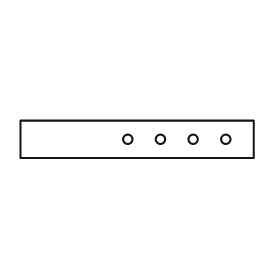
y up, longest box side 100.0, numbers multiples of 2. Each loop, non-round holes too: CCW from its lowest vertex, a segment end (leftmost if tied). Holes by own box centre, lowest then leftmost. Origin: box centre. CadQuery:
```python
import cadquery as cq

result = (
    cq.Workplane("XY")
    .moveTo(-50.0, -8.0)
    .lineTo(50.0, -8.0)
    .lineTo(50.0, 8.0)
    .lineTo(-50.0, 8.0)
    .close()
    .moveTo(-4.0, 0.0)
    .circle(2.0)
    .moveTo(10.0, 0.0)
    .circle(2.0)
    .moveTo(24.0, 0.0)
    .circle(2.0)
    .moveTo(38.0, 0.0)
    .circle(2.0)
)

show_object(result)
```